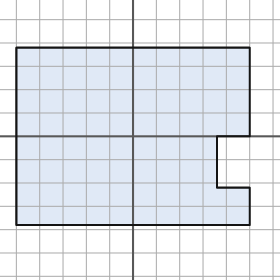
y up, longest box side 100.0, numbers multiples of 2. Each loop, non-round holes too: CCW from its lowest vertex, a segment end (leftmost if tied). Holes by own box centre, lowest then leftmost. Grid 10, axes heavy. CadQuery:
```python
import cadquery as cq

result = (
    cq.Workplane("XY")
    .moveTo(-50.0, -38.0)
    .lineTo(50.0, -38.0)
    .lineTo(50.0, -22.0)
    .lineTo(36.0, -22.0)
    .lineTo(36.0, 0.0)
    .lineTo(50.0, 0.0)
    .lineTo(50.0, 38.0)
    .lineTo(-50.0, 38.0)
    .close()
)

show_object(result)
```